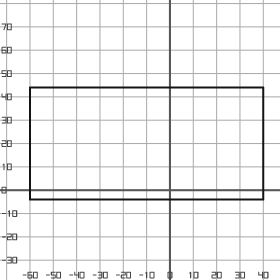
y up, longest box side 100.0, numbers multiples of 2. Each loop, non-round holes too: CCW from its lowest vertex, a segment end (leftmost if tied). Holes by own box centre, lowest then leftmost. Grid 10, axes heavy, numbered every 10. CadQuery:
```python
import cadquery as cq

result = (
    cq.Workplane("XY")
    .moveTo(-60.0, -4.0)
    .lineTo(40.0, -4.0)
    .lineTo(40.0, 44.0)
    .lineTo(-60.0, 44.0)
    .close()
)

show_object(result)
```